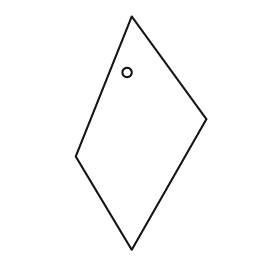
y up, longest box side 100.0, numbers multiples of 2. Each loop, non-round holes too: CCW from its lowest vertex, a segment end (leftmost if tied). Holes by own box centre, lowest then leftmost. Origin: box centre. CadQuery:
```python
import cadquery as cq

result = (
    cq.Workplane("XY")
    .moveTo(-4.0, -50.0)
    .lineTo(28.0, 6.0)
    .lineTo(-4.0, 50.0)
    .lineTo(-28.0, -10.0)
    .close()
    .moveTo(-6.0, 26.0)
    .circle(2.0)
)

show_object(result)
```